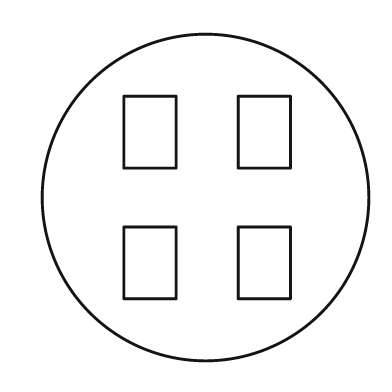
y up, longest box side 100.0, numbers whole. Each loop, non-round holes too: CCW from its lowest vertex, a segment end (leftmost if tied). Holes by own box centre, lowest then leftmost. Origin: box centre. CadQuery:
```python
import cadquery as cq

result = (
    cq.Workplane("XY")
    .moveTo(0.0, 0.0)
    .circle(50.0)
    .moveTo(-25.0, -31.0)
    .lineTo(-9.0, -31.0)
    .lineTo(-9.0, -9.0)
    .lineTo(-25.0, -9.0)
    .close()
    .moveTo(10.0, -31.0)
    .lineTo(26.0, -31.0)
    .lineTo(26.0, -9.0)
    .lineTo(10.0, -9.0)
    .close()
    .moveTo(-25.0, 9.0)
    .lineTo(-9.0, 9.0)
    .lineTo(-9.0, 31.0)
    .lineTo(-25.0, 31.0)
    .close()
    .moveTo(10.0, 9.0)
    .lineTo(26.0, 9.0)
    .lineTo(26.0, 31.0)
    .lineTo(10.0, 31.0)
    .close()
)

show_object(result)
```